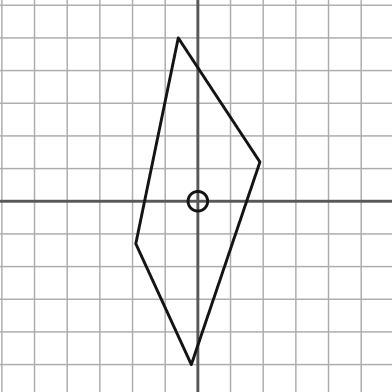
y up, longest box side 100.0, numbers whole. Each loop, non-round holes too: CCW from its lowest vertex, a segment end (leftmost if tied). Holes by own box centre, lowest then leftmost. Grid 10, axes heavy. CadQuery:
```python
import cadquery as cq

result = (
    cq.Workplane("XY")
    .moveTo(-2.0, -50.0)
    .lineTo(19.0, 12.0)
    .lineTo(-6.0, 50.0)
    .lineTo(-19.0, -13.0)
    .close()
    .moveTo(0.0, 0.0)
    .circle(3.0)
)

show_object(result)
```